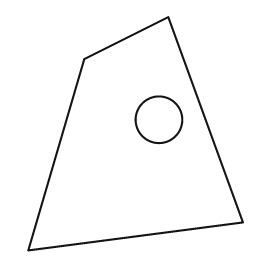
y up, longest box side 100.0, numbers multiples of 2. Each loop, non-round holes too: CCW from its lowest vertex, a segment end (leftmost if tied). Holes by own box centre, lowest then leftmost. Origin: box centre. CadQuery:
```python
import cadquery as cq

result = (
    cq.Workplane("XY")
    .moveTo(-46.0, -50.0)
    .lineTo(46.0, -38.0)
    .lineTo(14.0, 50.0)
    .lineTo(-22.0, 32.0)
    .close()
    .moveTo(10.0, 6.0)
    .circle(10.0)
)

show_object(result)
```